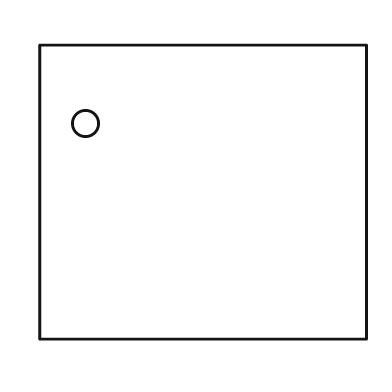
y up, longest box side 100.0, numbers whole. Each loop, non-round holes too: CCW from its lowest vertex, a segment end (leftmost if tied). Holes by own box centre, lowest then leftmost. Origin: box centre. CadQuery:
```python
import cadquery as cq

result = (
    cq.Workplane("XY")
    .moveTo(-50.0, -45.0)
    .lineTo(50.0, -45.0)
    .lineTo(50.0, 45.0)
    .lineTo(-50.0, 45.0)
    .close()
    .moveTo(-36.0, 21.0)
    .circle(4.0)
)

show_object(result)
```